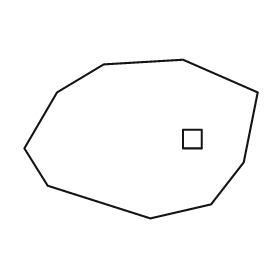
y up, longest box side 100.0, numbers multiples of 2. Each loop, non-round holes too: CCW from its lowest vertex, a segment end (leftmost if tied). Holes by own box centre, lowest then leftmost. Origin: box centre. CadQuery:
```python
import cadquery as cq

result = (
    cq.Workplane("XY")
    .moveTo(4.0, -34.0)
    .lineTo(30.0, -28.0)
    .lineTo(44.0, -10.0)
    .lineTo(50.0, 20.0)
    .lineTo(18.0, 34.0)
    .lineTo(-16.0, 32.0)
    .lineTo(-36.0, 20.0)
    .lineTo(-50.0, -4.0)
    .lineTo(-40.0, -20.0)
    .close()
    .moveTo(18.0, -4.0)
    .lineTo(26.0, -4.0)
    .lineTo(26.0, 4.0)
    .lineTo(18.0, 4.0)
    .close()
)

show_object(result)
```